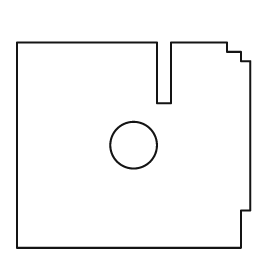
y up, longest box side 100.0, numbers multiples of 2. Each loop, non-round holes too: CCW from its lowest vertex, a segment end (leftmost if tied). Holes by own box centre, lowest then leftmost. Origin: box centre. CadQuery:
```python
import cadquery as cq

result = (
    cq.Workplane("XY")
    .moveTo(-50.0, -44.0)
    .lineTo(46.0, -44.0)
    .lineTo(46.0, -28.0)
    .lineTo(50.0, -28.0)
    .lineTo(50.0, 36.0)
    .lineTo(46.0, 36.0)
    .lineTo(46.0, 40.0)
    .lineTo(40.0, 40.0)
    .lineTo(40.0, 44.0)
    .lineTo(16.0, 44.0)
    .lineTo(16.0, 18.0)
    .lineTo(10.0, 18.0)
    .lineTo(10.0, 44.0)
    .lineTo(-50.0, 44.0)
    .close()
    .moveTo(0.0, 0.0)
    .circle(10.0)
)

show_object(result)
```